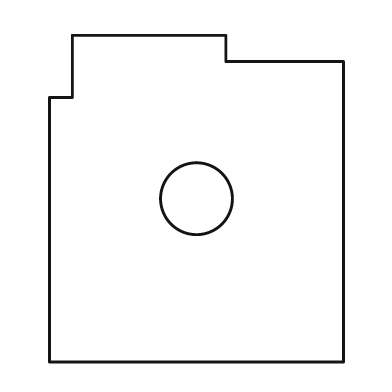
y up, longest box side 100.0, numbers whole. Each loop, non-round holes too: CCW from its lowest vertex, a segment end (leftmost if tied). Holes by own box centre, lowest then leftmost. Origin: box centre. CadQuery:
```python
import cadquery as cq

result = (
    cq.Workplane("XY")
    .moveTo(-45.0, -50.0)
    .lineTo(45.0, -50.0)
    .lineTo(45.0, 42.0)
    .lineTo(9.0, 42.0)
    .lineTo(9.0, 50.0)
    .lineTo(-38.0, 50.0)
    .lineTo(-38.0, 31.0)
    .lineTo(-45.0, 31.0)
    .close()
    .moveTo(0.0, 0.0)
    .circle(11.0)
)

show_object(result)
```